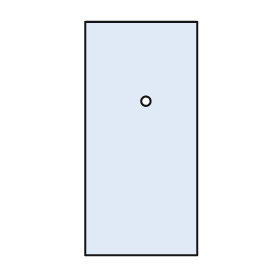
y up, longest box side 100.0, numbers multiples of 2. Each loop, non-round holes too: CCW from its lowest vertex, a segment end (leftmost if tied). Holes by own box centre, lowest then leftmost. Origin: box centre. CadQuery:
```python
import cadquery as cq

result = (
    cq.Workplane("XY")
    .moveTo(-24.0, -50.0)
    .lineTo(24.0, -50.0)
    .lineTo(24.0, 50.0)
    .lineTo(-24.0, 50.0)
    .close()
    .moveTo(2.0, 16.0)
    .circle(2.0)
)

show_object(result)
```